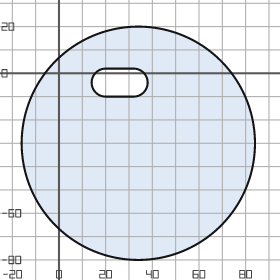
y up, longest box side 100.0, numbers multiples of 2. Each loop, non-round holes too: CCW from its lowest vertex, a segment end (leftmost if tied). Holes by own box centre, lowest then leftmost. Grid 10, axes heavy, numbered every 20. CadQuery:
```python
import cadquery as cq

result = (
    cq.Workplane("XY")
    .moveTo(34.0, -30.0)
    .circle(50.0)
    .moveTo(20.0, -10.0)
    .lineTo(32.0, -10.0)
    .threePointArc((38.0, -4.0), (32.0, 2.0))
    .lineTo(20.0, 2.0)
    .threePointArc((14.0, -4.0), (20.0, -10.0))
    .close()
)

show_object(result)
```